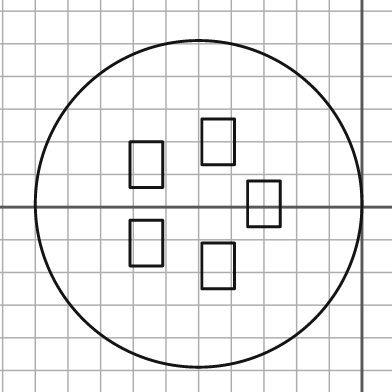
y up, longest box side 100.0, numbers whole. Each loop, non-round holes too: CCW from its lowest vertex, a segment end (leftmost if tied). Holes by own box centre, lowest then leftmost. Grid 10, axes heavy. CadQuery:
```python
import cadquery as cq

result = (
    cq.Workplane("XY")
    .moveTo(-50.0, 1.0)
    .circle(50.0)
    .moveTo(-49.0, -25.0)
    .lineTo(-39.0, -25.0)
    .lineTo(-39.0, -11.0)
    .lineTo(-49.0, -11.0)
    .close()
    .moveTo(-71.0, -18.0)
    .lineTo(-61.0, -18.0)
    .lineTo(-61.0, -4.0)
    .lineTo(-71.0, -4.0)
    .close()
    .moveTo(-35.0, -6.0)
    .lineTo(-25.0, -6.0)
    .lineTo(-25.0, 8.0)
    .lineTo(-35.0, 8.0)
    .close()
    .moveTo(-71.0, 6.0)
    .lineTo(-61.0, 6.0)
    .lineTo(-61.0, 20.0)
    .lineTo(-71.0, 20.0)
    .close()
    .moveTo(-49.0, 13.0)
    .lineTo(-39.0, 13.0)
    .lineTo(-39.0, 27.0)
    .lineTo(-49.0, 27.0)
    .close()
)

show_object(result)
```